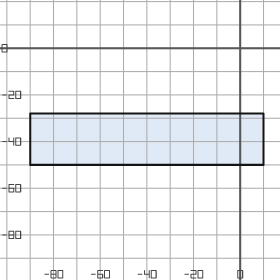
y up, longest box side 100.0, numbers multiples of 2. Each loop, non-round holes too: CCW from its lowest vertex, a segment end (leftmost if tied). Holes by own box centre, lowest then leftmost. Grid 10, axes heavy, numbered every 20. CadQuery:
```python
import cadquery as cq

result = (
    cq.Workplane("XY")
    .moveTo(-90.0, -50.0)
    .lineTo(10.0, -50.0)
    .lineTo(10.0, -28.0)
    .lineTo(-90.0, -28.0)
    .close()
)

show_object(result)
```